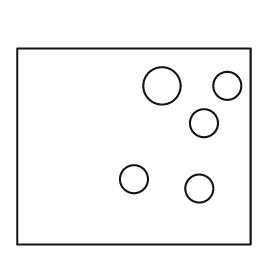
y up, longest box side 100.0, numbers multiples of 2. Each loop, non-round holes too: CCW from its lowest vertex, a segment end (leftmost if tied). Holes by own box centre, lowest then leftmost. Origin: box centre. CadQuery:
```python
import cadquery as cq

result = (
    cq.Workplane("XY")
    .moveTo(-50.0, -42.0)
    .lineTo(50.0, -42.0)
    .lineTo(50.0, 42.0)
    .lineTo(-50.0, 42.0)
    .close()
    .moveTo(28.0, -18.0)
    .circle(6.0)
    .moveTo(0.0, -14.0)
    .circle(6.0)
    .moveTo(30.0, 10.0)
    .circle(6.0)
    .moveTo(12.0, 26.0)
    .circle(8.0)
    .moveTo(40.0, 26.0)
    .circle(6.0)
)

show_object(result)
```